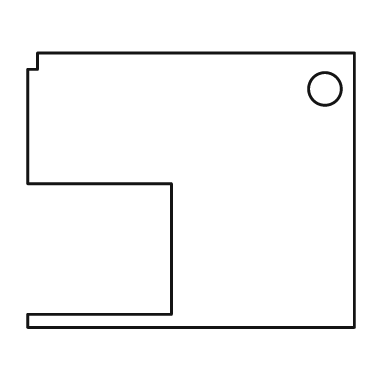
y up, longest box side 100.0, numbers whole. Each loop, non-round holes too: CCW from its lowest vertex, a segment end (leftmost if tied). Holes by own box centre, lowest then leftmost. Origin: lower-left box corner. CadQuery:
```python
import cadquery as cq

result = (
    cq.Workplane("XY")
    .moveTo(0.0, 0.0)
    .lineTo(100.0, 0.0)
    .lineTo(100.0, 84.0)
    .lineTo(3.0, 84.0)
    .lineTo(3.0, 79.0)
    .lineTo(0.0, 79.0)
    .lineTo(0.0, 44.0)
    .lineTo(44.0, 44.0)
    .lineTo(44.0, 4.0)
    .lineTo(0.0, 4.0)
    .close()
    .moveTo(91.0, 73.0)
    .circle(5.0)
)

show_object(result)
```